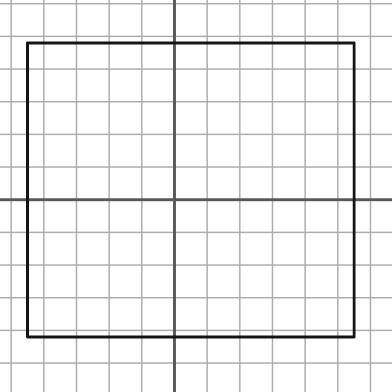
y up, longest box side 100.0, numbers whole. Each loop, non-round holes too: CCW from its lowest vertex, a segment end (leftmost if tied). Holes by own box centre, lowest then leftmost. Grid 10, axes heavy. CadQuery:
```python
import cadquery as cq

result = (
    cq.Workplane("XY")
    .moveTo(-45.0, -42.0)
    .lineTo(55.0, -42.0)
    .lineTo(55.0, 48.0)
    .lineTo(-45.0, 48.0)
    .close()
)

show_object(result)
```